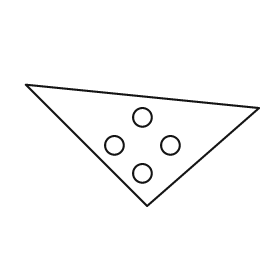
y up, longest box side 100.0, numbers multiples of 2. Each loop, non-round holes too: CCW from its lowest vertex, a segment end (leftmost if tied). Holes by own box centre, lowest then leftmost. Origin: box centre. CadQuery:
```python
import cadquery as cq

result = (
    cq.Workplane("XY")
    .moveTo(2.0, -26.0)
    .lineTo(50.0, 16.0)
    .lineTo(-50.0, 26.0)
    .close()
    .moveTo(0.0, -12.0)
    .circle(4.0)
    .moveTo(-12.0, 0.0)
    .circle(4.0)
    .moveTo(12.0, 0.0)
    .circle(4.0)
    .moveTo(0.0, 12.0)
    .circle(4.0)
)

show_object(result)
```